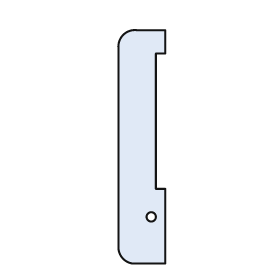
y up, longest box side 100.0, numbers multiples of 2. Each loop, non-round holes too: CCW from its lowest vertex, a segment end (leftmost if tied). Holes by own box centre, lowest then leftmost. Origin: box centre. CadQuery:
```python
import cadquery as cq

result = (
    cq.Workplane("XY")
    .moveTo(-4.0, -50.0)
    .lineTo(10.0, -50.0)
    .lineTo(10.0, -18.0)
    .lineTo(6.0, -18.0)
    .lineTo(6.0, 40.0)
    .lineTo(10.0, 40.0)
    .lineTo(10.0, 50.0)
    .lineTo(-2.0, 50.0)
    .threePointArc((-8.0, 48.0), (-10.0, 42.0))
    .lineTo(-10.0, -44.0)
    .threePointArc((-8.0, -48.0), (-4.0, -50.0))
    .close()
    .moveTo(4.0, -30.0)
    .circle(2.0)
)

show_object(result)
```